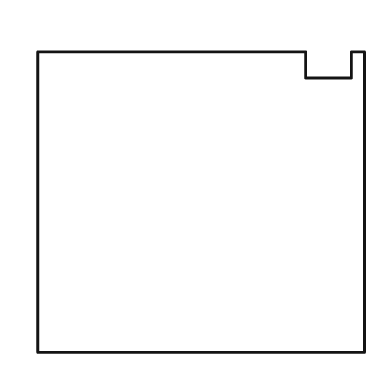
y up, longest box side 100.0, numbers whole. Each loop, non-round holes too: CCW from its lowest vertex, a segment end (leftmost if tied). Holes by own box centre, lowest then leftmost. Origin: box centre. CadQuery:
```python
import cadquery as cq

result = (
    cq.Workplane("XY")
    .moveTo(-50.0, -46.0)
    .lineTo(50.0, -46.0)
    .lineTo(50.0, 46.0)
    .lineTo(46.0, 46.0)
    .lineTo(46.0, 38.0)
    .lineTo(32.0, 38.0)
    .lineTo(32.0, 46.0)
    .lineTo(-50.0, 46.0)
    .close()
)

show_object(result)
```